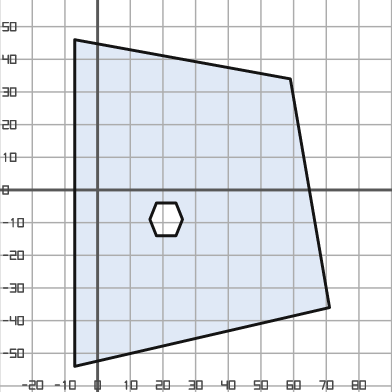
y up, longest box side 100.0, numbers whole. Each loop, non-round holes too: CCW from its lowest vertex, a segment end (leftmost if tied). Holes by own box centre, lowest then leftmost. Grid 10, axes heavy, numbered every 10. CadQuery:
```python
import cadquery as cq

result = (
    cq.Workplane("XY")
    .moveTo(-7.0, -54.0)
    .lineTo(71.0, -36.0)
    .lineTo(59.0, 34.0)
    .lineTo(-7.0, 46.0)
    .close()
    .moveTo(18.0, -14.0)
    .lineTo(24.0, -14.0)
    .lineTo(26.0, -9.0)
    .lineTo(24.0, -4.0)
    .lineTo(18.0, -4.0)
    .lineTo(16.0, -9.0)
    .close()
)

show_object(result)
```